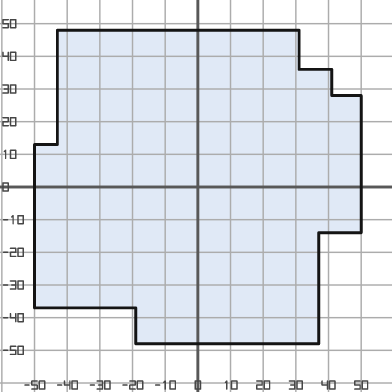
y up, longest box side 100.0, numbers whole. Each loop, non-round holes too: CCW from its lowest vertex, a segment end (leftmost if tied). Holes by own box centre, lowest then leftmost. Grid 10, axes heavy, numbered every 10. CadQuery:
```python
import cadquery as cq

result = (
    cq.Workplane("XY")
    .moveTo(-19.0, -48.0)
    .lineTo(37.0, -48.0)
    .lineTo(37.0, -14.0)
    .lineTo(50.0, -14.0)
    .lineTo(50.0, 28.0)
    .lineTo(41.0, 28.0)
    .lineTo(41.0, 36.0)
    .lineTo(31.0, 36.0)
    .lineTo(31.0, 48.0)
    .lineTo(-43.0, 48.0)
    .lineTo(-43.0, 13.0)
    .lineTo(-50.0, 13.0)
    .lineTo(-50.0, -37.0)
    .lineTo(-19.0, -37.0)
    .close()
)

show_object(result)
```